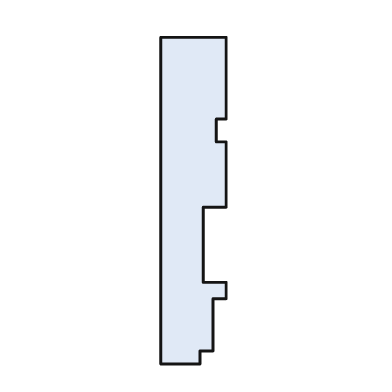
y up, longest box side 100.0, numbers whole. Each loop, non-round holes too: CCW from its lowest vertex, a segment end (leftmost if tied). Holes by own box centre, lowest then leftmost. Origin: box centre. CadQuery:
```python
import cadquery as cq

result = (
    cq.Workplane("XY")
    .moveTo(-10.0, -50.0)
    .lineTo(2.0, -50.0)
    .lineTo(2.0, -46.0)
    .lineTo(6.0, -46.0)
    .lineTo(6.0, -30.0)
    .lineTo(10.0, -30.0)
    .lineTo(10.0, -25.0)
    .lineTo(3.0, -25.0)
    .lineTo(3.0, -2.0)
    .lineTo(10.0, -2.0)
    .lineTo(10.0, 18.0)
    .lineTo(7.0, 18.0)
    .lineTo(7.0, 25.0)
    .lineTo(10.0, 25.0)
    .lineTo(10.0, 50.0)
    .lineTo(-10.0, 50.0)
    .close()
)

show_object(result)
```